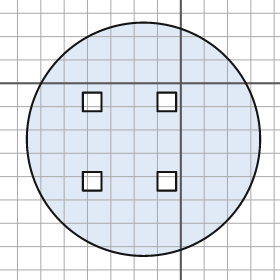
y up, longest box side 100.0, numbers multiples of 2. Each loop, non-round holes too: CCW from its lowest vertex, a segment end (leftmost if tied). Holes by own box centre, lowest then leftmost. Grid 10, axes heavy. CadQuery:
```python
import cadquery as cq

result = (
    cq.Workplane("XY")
    .moveTo(-16.0, -24.0)
    .circle(50.0)
    .moveTo(-42.0, -46.0)
    .lineTo(-34.0, -46.0)
    .lineTo(-34.0, -38.0)
    .lineTo(-42.0, -38.0)
    .close()
    .moveTo(-10.0, -46.0)
    .lineTo(-2.0, -46.0)
    .lineTo(-2.0, -38.0)
    .lineTo(-10.0, -38.0)
    .close()
    .moveTo(-42.0, -12.0)
    .lineTo(-34.0, -12.0)
    .lineTo(-34.0, -4.0)
    .lineTo(-42.0, -4.0)
    .close()
    .moveTo(-10.0, -12.0)
    .lineTo(-2.0, -12.0)
    .lineTo(-2.0, -4.0)
    .lineTo(-10.0, -4.0)
    .close()
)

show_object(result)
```